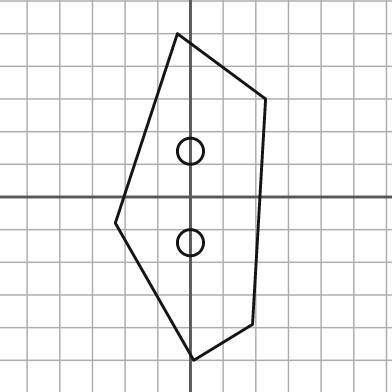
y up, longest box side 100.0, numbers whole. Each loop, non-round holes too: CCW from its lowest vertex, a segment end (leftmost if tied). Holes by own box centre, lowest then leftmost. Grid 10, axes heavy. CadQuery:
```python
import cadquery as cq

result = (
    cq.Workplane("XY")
    .moveTo(1.0, -50.0)
    .lineTo(19.0, -39.0)
    .lineTo(23.0, 30.0)
    .lineTo(-4.0, 50.0)
    .lineTo(-23.0, -8.0)
    .close()
    .moveTo(0.0, -14.0)
    .circle(4.0)
    .moveTo(0.0, 14.0)
    .circle(4.0)
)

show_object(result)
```